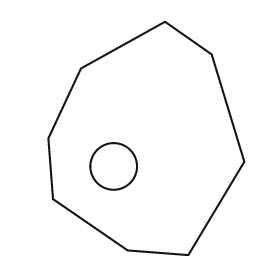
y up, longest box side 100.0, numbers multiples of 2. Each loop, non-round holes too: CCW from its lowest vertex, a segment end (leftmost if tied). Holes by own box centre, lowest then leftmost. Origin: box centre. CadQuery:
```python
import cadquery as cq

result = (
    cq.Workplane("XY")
    .moveTo(18.0, -50.0)
    .lineTo(42.0, -10.0)
    .lineTo(28.0, 36.0)
    .lineTo(8.0, 50.0)
    .lineTo(-28.0, 30.0)
    .lineTo(-42.0, 0.0)
    .lineTo(-40.0, -26.0)
    .lineTo(-8.0, -48.0)
    .close()
    .moveTo(-14.0, -12.0)
    .circle(10.0)
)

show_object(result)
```